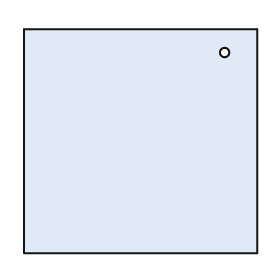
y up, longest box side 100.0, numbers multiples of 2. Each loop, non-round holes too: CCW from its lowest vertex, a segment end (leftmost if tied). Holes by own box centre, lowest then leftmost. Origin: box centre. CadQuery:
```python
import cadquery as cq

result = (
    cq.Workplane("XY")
    .moveTo(-50.0, -48.0)
    .lineTo(50.0, -48.0)
    .lineTo(50.0, 48.0)
    .lineTo(-50.0, 48.0)
    .close()
    .moveTo(36.0, 38.0)
    .circle(2.0)
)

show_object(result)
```